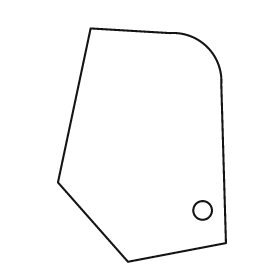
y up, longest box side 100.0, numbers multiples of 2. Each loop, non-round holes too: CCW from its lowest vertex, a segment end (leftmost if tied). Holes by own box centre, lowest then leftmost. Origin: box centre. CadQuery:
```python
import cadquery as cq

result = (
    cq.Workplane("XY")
    .moveTo(-6.0, -50.0)
    .lineTo(36.0, -42.0)
    .lineTo(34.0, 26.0)
    .threePointArc((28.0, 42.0), (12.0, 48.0))
    .lineTo(-22.0, 50.0)
    .lineTo(-36.0, -16.0)
    .close()
    .moveTo(26.0, -28.0)
    .circle(4.0)
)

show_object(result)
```